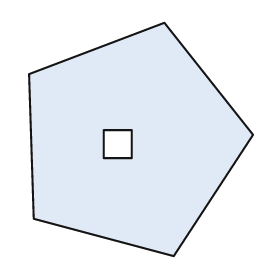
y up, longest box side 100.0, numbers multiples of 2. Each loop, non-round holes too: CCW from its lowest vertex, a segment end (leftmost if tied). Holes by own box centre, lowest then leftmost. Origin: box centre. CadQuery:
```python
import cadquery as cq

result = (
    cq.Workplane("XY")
    .moveTo(14.0, -50.0)
    .lineTo(48.0, 2.0)
    .lineTo(10.0, 50.0)
    .lineTo(-48.0, 28.0)
    .lineTo(-46.0, -34.0)
    .close()
    .moveTo(-16.0, -8.0)
    .lineTo(-4.0, -8.0)
    .lineTo(-4.0, 4.0)
    .lineTo(-16.0, 4.0)
    .close()
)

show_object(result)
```